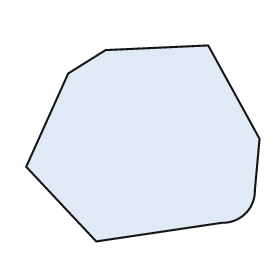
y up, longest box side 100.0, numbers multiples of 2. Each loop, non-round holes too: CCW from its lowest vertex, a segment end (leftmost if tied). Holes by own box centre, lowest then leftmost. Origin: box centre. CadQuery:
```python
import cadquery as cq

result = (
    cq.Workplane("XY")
    .moveTo(-20.0, -42.0)
    .lineTo(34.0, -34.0)
    .threePointArc((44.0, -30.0), (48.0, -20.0))
    .lineTo(50.0, 2.0)
    .lineTo(28.0, 42.0)
    .lineTo(-16.0, 40.0)
    .lineTo(-32.0, 30.0)
    .lineTo(-50.0, -10.0)
    .close()
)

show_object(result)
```